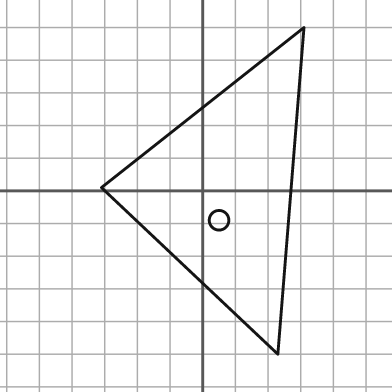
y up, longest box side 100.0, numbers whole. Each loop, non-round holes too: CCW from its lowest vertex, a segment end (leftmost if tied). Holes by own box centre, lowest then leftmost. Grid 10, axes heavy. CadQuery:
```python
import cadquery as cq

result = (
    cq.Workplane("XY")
    .moveTo(23.0, -50.0)
    .lineTo(31.0, 50.0)
    .lineTo(-31.0, 1.0)
    .close()
    .moveTo(5.0, -9.0)
    .circle(3.0)
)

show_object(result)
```